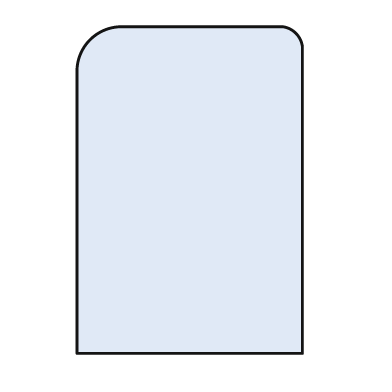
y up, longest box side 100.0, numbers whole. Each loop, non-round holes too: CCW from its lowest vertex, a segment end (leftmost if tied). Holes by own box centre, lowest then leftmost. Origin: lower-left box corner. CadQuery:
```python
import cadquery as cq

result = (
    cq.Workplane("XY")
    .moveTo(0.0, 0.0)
    .lineTo(69.0, 0.0)
    .lineTo(69.0, 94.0)
    .threePointArc((67.0, 98.0), (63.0, 100.0))
    .lineTo(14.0, 100.0)
    .threePointArc((4.0, 96.0), (0.0, 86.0))
    .close()
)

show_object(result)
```